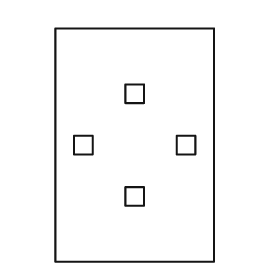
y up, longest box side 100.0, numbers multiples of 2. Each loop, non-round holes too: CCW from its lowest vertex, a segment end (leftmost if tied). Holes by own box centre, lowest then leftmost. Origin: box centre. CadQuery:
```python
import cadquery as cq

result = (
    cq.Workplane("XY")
    .moveTo(-34.0, -50.0)
    .lineTo(34.0, -50.0)
    .lineTo(34.0, 50.0)
    .lineTo(-34.0, 50.0)
    .close()
    .moveTo(-4.0, -26.0)
    .lineTo(4.0, -26.0)
    .lineTo(4.0, -18.0)
    .lineTo(-4.0, -18.0)
    .close()
    .moveTo(-26.0, -4.0)
    .lineTo(-18.0, -4.0)
    .lineTo(-18.0, 4.0)
    .lineTo(-26.0, 4.0)
    .close()
    .moveTo(18.0, -4.0)
    .lineTo(26.0, -4.0)
    .lineTo(26.0, 4.0)
    .lineTo(18.0, 4.0)
    .close()
    .moveTo(-4.0, 18.0)
    .lineTo(4.0, 18.0)
    .lineTo(4.0, 26.0)
    .lineTo(-4.0, 26.0)
    .close()
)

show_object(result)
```